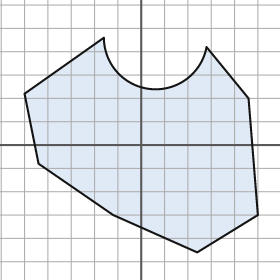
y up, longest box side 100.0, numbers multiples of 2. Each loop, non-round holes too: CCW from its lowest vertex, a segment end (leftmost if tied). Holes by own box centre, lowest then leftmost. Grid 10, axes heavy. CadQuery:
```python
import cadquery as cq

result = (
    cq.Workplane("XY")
    .moveTo(24.0, -46.0)
    .lineTo(50.0, -30.0)
    .lineTo(46.0, 20.0)
    .lineTo(28.0, 42.0)
    .threePointArc((4.0, 24.0), (-16.0, 46.0))
    .lineTo(-50.0, 22.0)
    .lineTo(-44.0, -8.0)
    .lineTo(-12.0, -30.0)
    .close()
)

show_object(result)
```